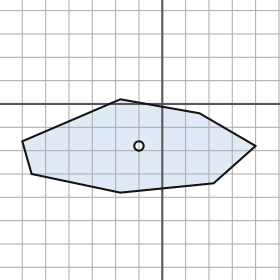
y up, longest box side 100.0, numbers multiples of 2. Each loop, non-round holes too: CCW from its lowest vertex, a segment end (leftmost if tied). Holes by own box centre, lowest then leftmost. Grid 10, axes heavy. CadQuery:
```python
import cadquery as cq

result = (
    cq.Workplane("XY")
    .moveTo(-18.0, -38.0)
    .lineTo(22.0, -34.0)
    .lineTo(40.0, -18.0)
    .lineTo(16.0, -4.0)
    .lineTo(-18.0, 2.0)
    .lineTo(-60.0, -16.0)
    .lineTo(-56.0, -30.0)
    .close()
    .moveTo(-10.0, -18.0)
    .circle(2.0)
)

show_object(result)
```